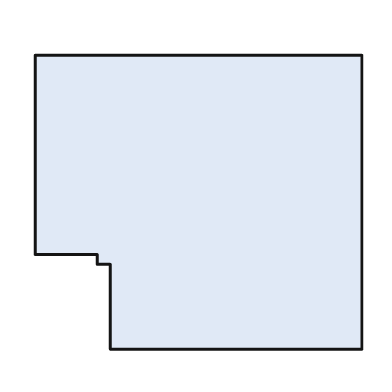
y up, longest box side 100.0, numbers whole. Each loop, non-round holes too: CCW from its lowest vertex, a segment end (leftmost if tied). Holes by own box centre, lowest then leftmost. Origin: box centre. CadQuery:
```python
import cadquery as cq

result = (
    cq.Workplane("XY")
    .moveTo(-27.0, -45.0)
    .lineTo(50.0, -45.0)
    .lineTo(50.0, 45.0)
    .lineTo(-50.0, 45.0)
    .lineTo(-50.0, -16.0)
    .lineTo(-31.0, -16.0)
    .lineTo(-31.0, -19.0)
    .lineTo(-27.0, -19.0)
    .close()
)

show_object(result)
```